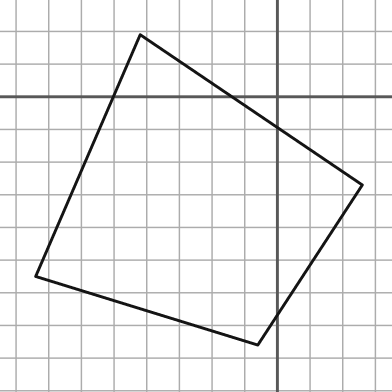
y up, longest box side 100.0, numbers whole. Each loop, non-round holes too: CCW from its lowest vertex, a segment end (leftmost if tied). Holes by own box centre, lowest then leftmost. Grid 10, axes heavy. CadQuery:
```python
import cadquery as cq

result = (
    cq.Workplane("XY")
    .moveTo(-6.0, -76.0)
    .lineTo(26.0, -27.0)
    .lineTo(-42.0, 19.0)
    .lineTo(-74.0, -55.0)
    .close()
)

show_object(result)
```